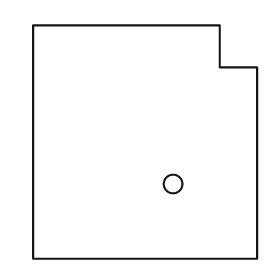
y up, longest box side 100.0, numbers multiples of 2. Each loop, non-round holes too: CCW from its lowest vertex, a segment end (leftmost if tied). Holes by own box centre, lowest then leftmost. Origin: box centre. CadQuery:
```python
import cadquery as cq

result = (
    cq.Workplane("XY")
    .moveTo(-48.0, -50.0)
    .lineTo(48.0, -50.0)
    .lineTo(48.0, 32.0)
    .lineTo(32.0, 32.0)
    .lineTo(32.0, 50.0)
    .lineTo(-48.0, 50.0)
    .close()
    .moveTo(12.0, -18.0)
    .circle(4.0)
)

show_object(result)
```